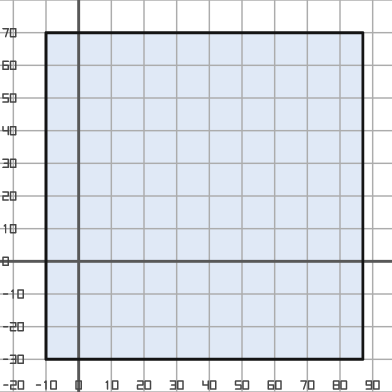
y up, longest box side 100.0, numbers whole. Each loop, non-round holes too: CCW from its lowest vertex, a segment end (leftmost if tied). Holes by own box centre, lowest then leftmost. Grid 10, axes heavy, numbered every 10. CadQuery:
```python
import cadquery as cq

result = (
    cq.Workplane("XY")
    .moveTo(-10.0, -30.0)
    .lineTo(87.0, -30.0)
    .lineTo(87.0, 70.0)
    .lineTo(-10.0, 70.0)
    .close()
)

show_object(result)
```